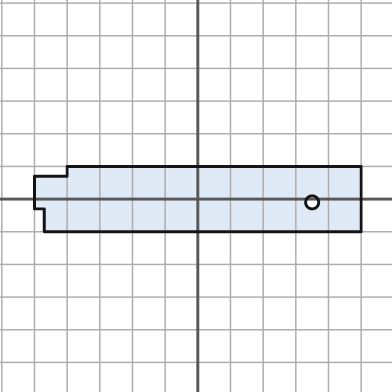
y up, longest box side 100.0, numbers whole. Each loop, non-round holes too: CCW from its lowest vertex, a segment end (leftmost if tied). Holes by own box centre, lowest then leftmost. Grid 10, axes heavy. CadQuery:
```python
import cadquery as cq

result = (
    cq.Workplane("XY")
    .moveTo(-47.0, -10.0)
    .lineTo(50.0, -10.0)
    .lineTo(50.0, 10.0)
    .lineTo(-40.0, 10.0)
    .lineTo(-40.0, 7.0)
    .lineTo(-50.0, 7.0)
    .lineTo(-50.0, -3.0)
    .lineTo(-47.0, -3.0)
    .close()
    .moveTo(35.0, -1.0)
    .circle(2.0)
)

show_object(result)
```